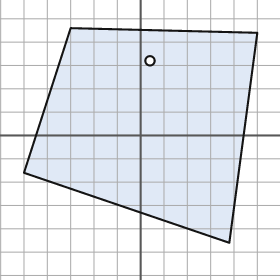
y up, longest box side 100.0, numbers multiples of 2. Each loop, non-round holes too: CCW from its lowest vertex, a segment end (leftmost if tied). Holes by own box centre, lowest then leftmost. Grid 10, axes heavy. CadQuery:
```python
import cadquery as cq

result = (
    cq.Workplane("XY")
    .moveTo(38.0, -46.0)
    .lineTo(50.0, 44.0)
    .lineTo(-30.0, 46.0)
    .lineTo(-50.0, -16.0)
    .close()
    .moveTo(4.0, 32.0)
    .circle(2.0)
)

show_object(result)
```